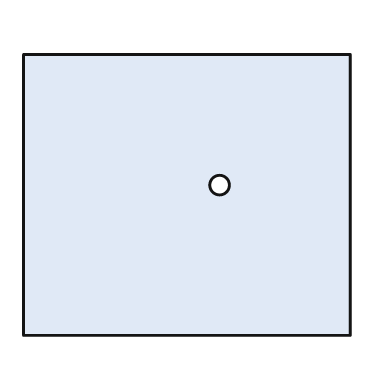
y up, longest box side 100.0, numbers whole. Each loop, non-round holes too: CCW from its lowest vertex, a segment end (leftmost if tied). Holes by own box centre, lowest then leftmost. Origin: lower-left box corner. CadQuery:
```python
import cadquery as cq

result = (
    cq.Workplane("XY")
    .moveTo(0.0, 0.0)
    .lineTo(100.0, 0.0)
    .lineTo(100.0, 86.0)
    .lineTo(0.0, 86.0)
    .close()
    .moveTo(60.0, 46.0)
    .circle(3.0)
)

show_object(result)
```